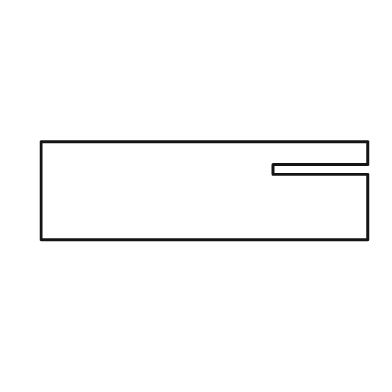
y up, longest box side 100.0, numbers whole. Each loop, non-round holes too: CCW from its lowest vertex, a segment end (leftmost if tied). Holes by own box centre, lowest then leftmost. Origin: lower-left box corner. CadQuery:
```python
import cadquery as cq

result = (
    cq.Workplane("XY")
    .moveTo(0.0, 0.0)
    .lineTo(100.0, 0.0)
    .lineTo(100.0, 20.0)
    .lineTo(71.0, 20.0)
    .lineTo(71.0, 23.0)
    .lineTo(100.0, 23.0)
    .lineTo(100.0, 30.0)
    .lineTo(0.0, 30.0)
    .close()
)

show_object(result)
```